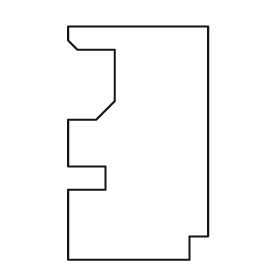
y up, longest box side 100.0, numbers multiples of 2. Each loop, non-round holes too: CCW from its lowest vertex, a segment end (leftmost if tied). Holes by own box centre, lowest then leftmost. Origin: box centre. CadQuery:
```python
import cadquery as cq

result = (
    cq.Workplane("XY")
    .moveTo(-30.0, -50.0)
    .lineTo(22.0, -50.0)
    .lineTo(22.0, -40.0)
    .lineTo(30.0, -40.0)
    .lineTo(30.0, 50.0)
    .lineTo(-30.0, 50.0)
    .lineTo(-30.0, 44.0)
    .lineTo(-26.0, 40.0)
    .lineTo(-10.0, 40.0)
    .lineTo(-10.0, 18.0)
    .lineTo(-18.0, 10.0)
    .lineTo(-30.0, 10.0)
    .lineTo(-30.0, -10.0)
    .lineTo(-14.0, -10.0)
    .lineTo(-14.0, -20.0)
    .lineTo(-30.0, -20.0)
    .close()
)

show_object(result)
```